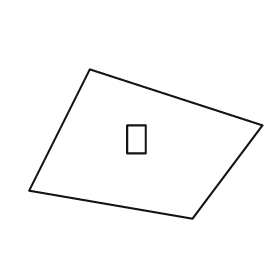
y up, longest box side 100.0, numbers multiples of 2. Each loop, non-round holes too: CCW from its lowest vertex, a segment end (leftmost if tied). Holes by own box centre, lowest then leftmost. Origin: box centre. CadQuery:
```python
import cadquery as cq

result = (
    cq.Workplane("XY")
    .moveTo(20.0, -32.0)
    .lineTo(50.0, 8.0)
    .lineTo(-24.0, 32.0)
    .lineTo(-50.0, -20.0)
    .close()
    .moveTo(-8.0, -4.0)
    .lineTo(0.0, -4.0)
    .lineTo(0.0, 8.0)
    .lineTo(-8.0, 8.0)
    .close()
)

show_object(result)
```